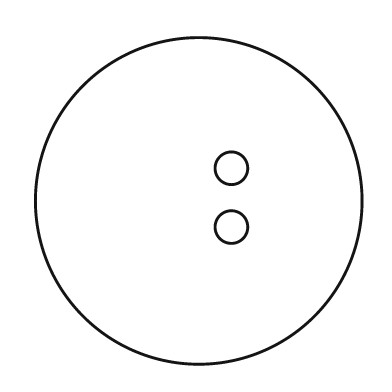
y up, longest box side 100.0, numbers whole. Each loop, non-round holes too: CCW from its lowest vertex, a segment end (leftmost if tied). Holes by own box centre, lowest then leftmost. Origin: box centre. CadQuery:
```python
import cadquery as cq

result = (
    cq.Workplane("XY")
    .moveTo(0.0, 0.0)
    .circle(50.0)
    .moveTo(10.0, -8.0)
    .circle(5.0)
    .moveTo(10.0, 10.0)
    .circle(5.0)
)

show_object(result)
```